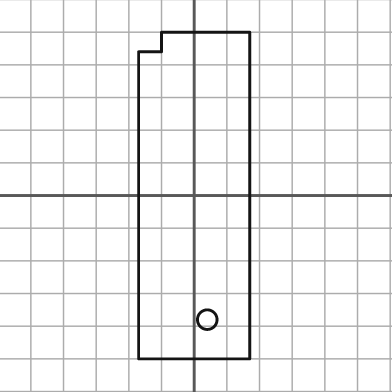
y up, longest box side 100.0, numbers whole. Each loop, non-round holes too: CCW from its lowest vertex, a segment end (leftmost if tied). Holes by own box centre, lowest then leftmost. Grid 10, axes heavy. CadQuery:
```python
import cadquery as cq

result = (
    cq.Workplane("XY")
    .moveTo(-17.0, -50.0)
    .lineTo(17.0, -50.0)
    .lineTo(17.0, 50.0)
    .lineTo(-10.0, 50.0)
    .lineTo(-10.0, 44.0)
    .lineTo(-17.0, 44.0)
    .close()
    .moveTo(4.0, -38.0)
    .circle(3.0)
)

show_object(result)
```